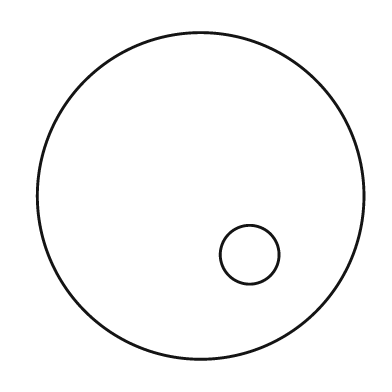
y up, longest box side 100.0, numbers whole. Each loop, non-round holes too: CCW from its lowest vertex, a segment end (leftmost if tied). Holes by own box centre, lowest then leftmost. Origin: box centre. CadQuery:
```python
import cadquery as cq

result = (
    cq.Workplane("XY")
    .moveTo(0.0, 0.0)
    .circle(50.0)
    .moveTo(15.0, -18.0)
    .circle(9.0)
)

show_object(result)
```